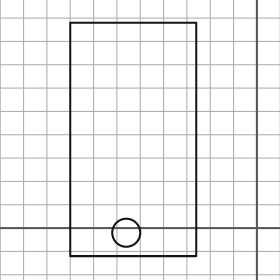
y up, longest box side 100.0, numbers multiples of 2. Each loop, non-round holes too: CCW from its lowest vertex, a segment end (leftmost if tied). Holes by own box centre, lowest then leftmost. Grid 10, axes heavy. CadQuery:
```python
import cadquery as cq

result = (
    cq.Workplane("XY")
    .moveTo(-80.0, -12.0)
    .lineTo(-26.0, -12.0)
    .lineTo(-26.0, 88.0)
    .lineTo(-80.0, 88.0)
    .close()
    .moveTo(-56.0, -2.0)
    .circle(6.0)
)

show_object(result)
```